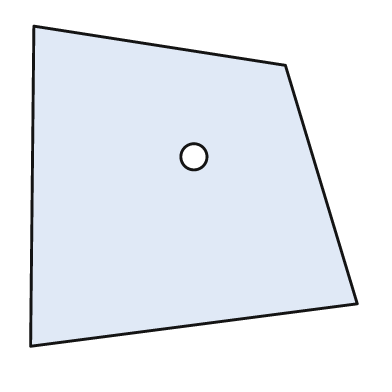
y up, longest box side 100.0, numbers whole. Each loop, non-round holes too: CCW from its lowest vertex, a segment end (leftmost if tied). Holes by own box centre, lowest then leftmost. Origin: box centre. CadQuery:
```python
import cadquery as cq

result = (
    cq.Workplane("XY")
    .moveTo(-50.0, -49.0)
    .lineTo(50.0, -36.0)
    .lineTo(28.0, 37.0)
    .lineTo(-49.0, 49.0)
    .close()
    .moveTo(0.0, 9.0)
    .circle(4.0)
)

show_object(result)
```